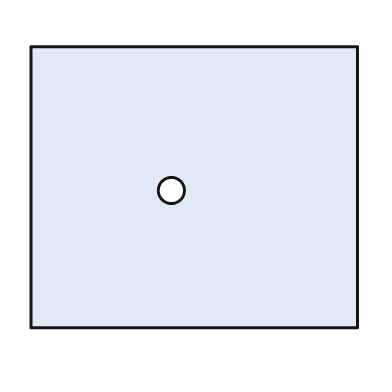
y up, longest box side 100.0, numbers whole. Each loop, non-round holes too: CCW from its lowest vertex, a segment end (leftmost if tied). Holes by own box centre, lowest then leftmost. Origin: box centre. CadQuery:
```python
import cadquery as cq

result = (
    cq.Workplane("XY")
    .moveTo(-50.0, -43.0)
    .lineTo(50.0, -43.0)
    .lineTo(50.0, 43.0)
    .lineTo(-50.0, 43.0)
    .close()
    .moveTo(-7.0, -1.0)
    .circle(4.0)
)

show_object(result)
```